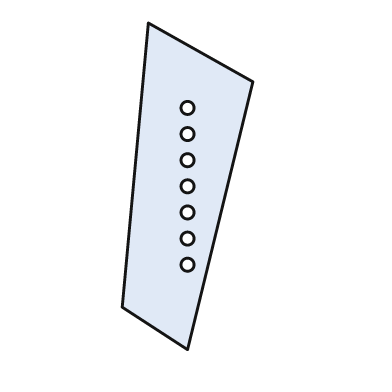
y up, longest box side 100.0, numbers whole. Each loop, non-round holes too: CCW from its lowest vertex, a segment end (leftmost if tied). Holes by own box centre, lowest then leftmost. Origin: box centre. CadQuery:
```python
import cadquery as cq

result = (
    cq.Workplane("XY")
    .moveTo(0.0, -50.0)
    .lineTo(20.0, 32.0)
    .lineTo(-12.0, 50.0)
    .lineTo(-20.0, -37.0)
    .close()
    .moveTo(0.0, -24.0)
    .circle(2.0)
    .moveTo(0.0, -16.0)
    .circle(2.0)
    .moveTo(0.0, -8.0)
    .circle(2.0)
    .moveTo(0.0, 0.0)
    .circle(2.0)
    .moveTo(0.0, 8.0)
    .circle(2.0)
    .moveTo(0.0, 16.0)
    .circle(2.0)
    .moveTo(0.0, 24.0)
    .circle(2.0)
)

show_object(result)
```